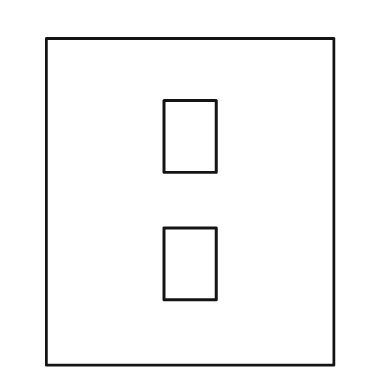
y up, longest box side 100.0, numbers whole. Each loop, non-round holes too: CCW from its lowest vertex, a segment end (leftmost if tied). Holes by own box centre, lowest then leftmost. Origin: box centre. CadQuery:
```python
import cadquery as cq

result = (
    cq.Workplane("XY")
    .moveTo(-44.0, -50.0)
    .lineTo(44.0, -50.0)
    .lineTo(44.0, 50.0)
    .lineTo(-44.0, 50.0)
    .close()
    .moveTo(-8.0, -30.0)
    .lineTo(8.0, -30.0)
    .lineTo(8.0, -8.0)
    .lineTo(-8.0, -8.0)
    .close()
    .moveTo(-8.0, 9.0)
    .lineTo(8.0, 9.0)
    .lineTo(8.0, 31.0)
    .lineTo(-8.0, 31.0)
    .close()
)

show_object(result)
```